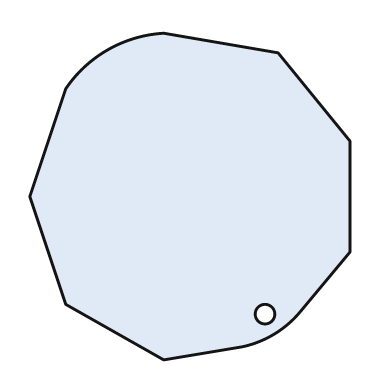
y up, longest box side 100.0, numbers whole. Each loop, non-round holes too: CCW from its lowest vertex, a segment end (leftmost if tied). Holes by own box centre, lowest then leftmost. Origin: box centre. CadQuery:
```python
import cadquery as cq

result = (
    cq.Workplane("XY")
    .moveTo(-8.0, -50.0)
    .lineTo(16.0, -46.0)
    .threePointArc((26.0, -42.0), (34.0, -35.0))
    .lineTo(49.0, -17.0)
    .lineTo(49.0, 17.0)
    .lineTo(27.0, 44.0)
    .lineTo(-8.0, 50.0)
    .threePointArc((-25.0, 45.0), (-38.0, 33.0))
    .lineTo(-49.0, 0.0)
    .lineTo(-38.0, -33.0)
    .close()
    .moveTo(23.0, -36.0)
    .circle(3.0)
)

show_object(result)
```